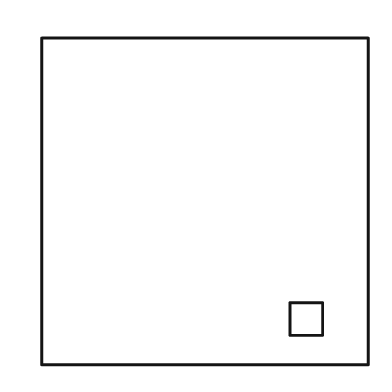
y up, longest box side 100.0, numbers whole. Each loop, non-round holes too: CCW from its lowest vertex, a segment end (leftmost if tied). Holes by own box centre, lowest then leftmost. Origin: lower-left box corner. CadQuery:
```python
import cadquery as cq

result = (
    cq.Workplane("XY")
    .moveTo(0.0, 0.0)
    .lineTo(100.0, 0.0)
    .lineTo(100.0, 100.0)
    .lineTo(0.0, 100.0)
    .close()
    .moveTo(76.0, 9.0)
    .lineTo(86.0, 9.0)
    .lineTo(86.0, 19.0)
    .lineTo(76.0, 19.0)
    .close()
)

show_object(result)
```